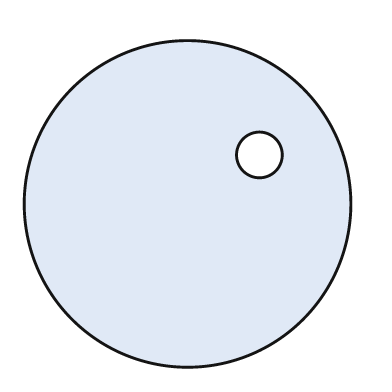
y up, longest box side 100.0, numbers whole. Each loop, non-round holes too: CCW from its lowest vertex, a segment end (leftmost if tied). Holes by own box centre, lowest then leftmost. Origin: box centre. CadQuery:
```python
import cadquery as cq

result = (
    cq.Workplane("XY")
    .moveTo(0.0, 0.0)
    .circle(50.0)
    .moveTo(22.0, 15.0)
    .circle(7.0)
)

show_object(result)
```